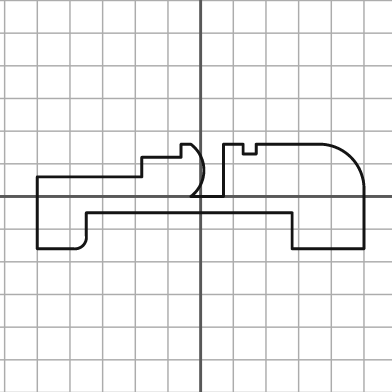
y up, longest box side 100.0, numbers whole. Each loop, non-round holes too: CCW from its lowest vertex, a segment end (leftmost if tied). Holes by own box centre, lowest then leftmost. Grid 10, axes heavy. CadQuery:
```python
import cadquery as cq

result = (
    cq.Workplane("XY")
    .moveTo(-50.0, -16.0)
    .lineTo(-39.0, -16.0)
    .threePointArc((-36.0, -15.0), (-35.0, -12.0))
    .lineTo(-35.0, -5.0)
    .lineTo(28.0, -5.0)
    .lineTo(28.0, -16.0)
    .lineTo(50.0, -16.0)
    .lineTo(50.0, 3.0)
    .threePointArc((46.0, 12.0), (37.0, 16.0))
    .lineTo(17.0, 16.0)
    .lineTo(17.0, 13.0)
    .lineTo(13.0, 13.0)
    .lineTo(13.0, 16.0)
    .lineTo(7.0, 16.0)
    .lineTo(7.0, 0.0)
    .lineTo(-3.0, 0.0)
    .threePointArc((1.0, 8.0), (-3.0, 16.0))
    .lineTo(-6.0, 16.0)
    .lineTo(-6.0, 12.0)
    .lineTo(-18.0, 12.0)
    .lineTo(-18.0, 6.0)
    .lineTo(-50.0, 6.0)
    .close()
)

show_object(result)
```